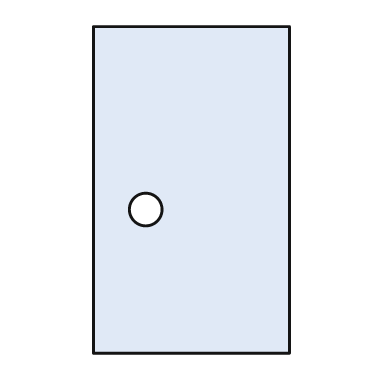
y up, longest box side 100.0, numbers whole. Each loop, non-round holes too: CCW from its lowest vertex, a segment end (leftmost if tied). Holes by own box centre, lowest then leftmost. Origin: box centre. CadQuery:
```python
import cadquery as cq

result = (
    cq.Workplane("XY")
    .moveTo(-30.0, -50.0)
    .lineTo(30.0, -50.0)
    .lineTo(30.0, 50.0)
    .lineTo(-30.0, 50.0)
    .close()
    .moveTo(-14.0, -6.0)
    .circle(5.0)
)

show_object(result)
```